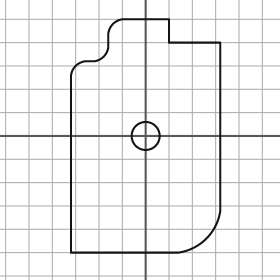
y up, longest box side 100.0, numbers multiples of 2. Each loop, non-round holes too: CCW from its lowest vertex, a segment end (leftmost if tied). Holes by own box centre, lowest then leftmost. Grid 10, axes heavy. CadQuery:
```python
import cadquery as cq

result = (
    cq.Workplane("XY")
    .moveTo(-32.0, -50.0)
    .lineTo(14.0, -50.0)
    .threePointArc((26.0, -44.0), (32.0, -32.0))
    .lineTo(32.0, 40.0)
    .lineTo(10.0, 40.0)
    .lineTo(10.0, 50.0)
    .lineTo(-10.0, 50.0)
    .threePointArc((-14.0, 48.0), (-16.0, 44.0))
    .lineTo(-16.0, 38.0)
    .threePointArc((-18.0, 34.0), (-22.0, 32.0))
    .lineTo(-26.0, 32.0)
    .threePointArc((-30.0, 30.0), (-32.0, 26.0))
    .close()
    .moveTo(0.0, 0.0)
    .circle(6.0)
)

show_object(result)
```